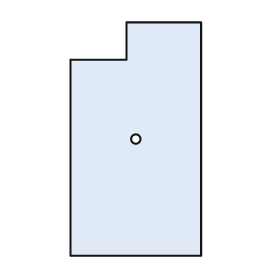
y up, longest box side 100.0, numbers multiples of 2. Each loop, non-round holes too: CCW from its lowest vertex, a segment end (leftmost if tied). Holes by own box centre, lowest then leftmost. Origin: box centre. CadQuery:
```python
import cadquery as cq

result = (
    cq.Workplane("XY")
    .moveTo(-28.0, -50.0)
    .lineTo(28.0, -50.0)
    .lineTo(28.0, 50.0)
    .lineTo(-4.0, 50.0)
    .lineTo(-4.0, 34.0)
    .lineTo(-28.0, 34.0)
    .close()
    .moveTo(0.0, 0.0)
    .circle(2.0)
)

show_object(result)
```